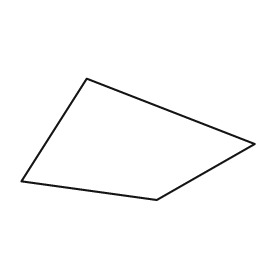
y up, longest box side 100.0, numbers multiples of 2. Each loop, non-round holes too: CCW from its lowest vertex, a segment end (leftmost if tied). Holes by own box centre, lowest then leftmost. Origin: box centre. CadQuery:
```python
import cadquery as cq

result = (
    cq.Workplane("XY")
    .moveTo(8.0, -26.0)
    .lineTo(50.0, -2.0)
    .lineTo(-22.0, 26.0)
    .lineTo(-50.0, -18.0)
    .close()
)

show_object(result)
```